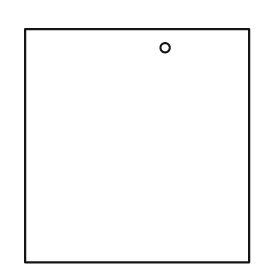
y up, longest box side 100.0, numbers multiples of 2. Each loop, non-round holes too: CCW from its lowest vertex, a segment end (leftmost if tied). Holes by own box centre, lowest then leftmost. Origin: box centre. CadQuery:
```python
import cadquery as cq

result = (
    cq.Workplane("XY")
    .moveTo(-48.0, -50.0)
    .lineTo(48.0, -50.0)
    .lineTo(48.0, 50.0)
    .lineTo(-48.0, 50.0)
    .close()
    .moveTo(12.0, 42.0)
    .circle(2.0)
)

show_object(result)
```